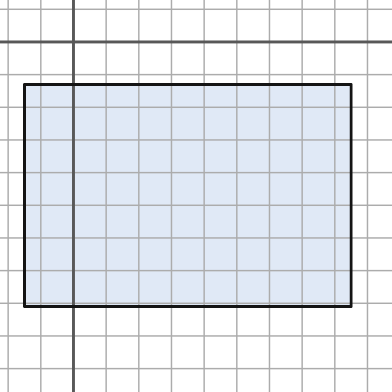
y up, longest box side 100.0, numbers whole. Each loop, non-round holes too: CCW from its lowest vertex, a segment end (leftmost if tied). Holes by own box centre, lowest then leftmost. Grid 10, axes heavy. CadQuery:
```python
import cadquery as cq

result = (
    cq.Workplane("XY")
    .moveTo(-15.0, -81.0)
    .lineTo(85.0, -81.0)
    .lineTo(85.0, -13.0)
    .lineTo(-15.0, -13.0)
    .close()
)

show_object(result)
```